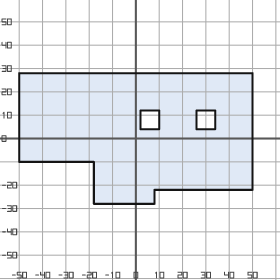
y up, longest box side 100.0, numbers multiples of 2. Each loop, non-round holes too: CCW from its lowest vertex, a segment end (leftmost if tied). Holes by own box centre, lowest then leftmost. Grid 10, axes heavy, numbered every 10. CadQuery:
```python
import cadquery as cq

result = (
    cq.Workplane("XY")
    .moveTo(-18.0, -28.0)
    .lineTo(8.0, -28.0)
    .lineTo(8.0, -22.0)
    .lineTo(50.0, -22.0)
    .lineTo(50.0, 28.0)
    .lineTo(-50.0, 28.0)
    .lineTo(-50.0, -10.0)
    .lineTo(-18.0, -10.0)
    .close()
    .moveTo(2.0, 4.0)
    .lineTo(10.0, 4.0)
    .lineTo(10.0, 12.0)
    .lineTo(2.0, 12.0)
    .close()
    .moveTo(26.0, 4.0)
    .lineTo(34.0, 4.0)
    .lineTo(34.0, 12.0)
    .lineTo(26.0, 12.0)
    .close()
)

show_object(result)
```